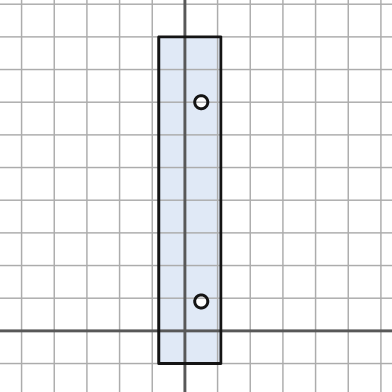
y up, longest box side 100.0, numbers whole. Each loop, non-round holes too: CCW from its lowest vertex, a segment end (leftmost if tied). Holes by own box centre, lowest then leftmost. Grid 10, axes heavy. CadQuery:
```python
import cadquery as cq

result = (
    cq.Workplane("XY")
    .moveTo(-8.0, -10.0)
    .lineTo(11.0, -10.0)
    .lineTo(11.0, 90.0)
    .lineTo(-8.0, 90.0)
    .close()
    .moveTo(5.0, 9.0)
    .circle(2.0)
    .moveTo(5.0, 70.0)
    .circle(2.0)
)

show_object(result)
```